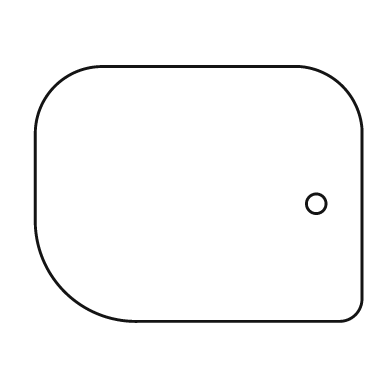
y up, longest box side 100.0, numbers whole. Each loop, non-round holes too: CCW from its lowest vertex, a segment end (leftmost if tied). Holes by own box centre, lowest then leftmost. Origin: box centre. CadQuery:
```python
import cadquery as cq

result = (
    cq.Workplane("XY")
    .moveTo(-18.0, -39.0)
    .lineTo(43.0, -39.0)
    .threePointArc((48.0, -37.0), (50.0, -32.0))
    .lineTo(50.0, 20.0)
    .threePointArc((44.0, 33.0), (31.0, 39.0))
    .lineTo(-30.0, 39.0)
    .threePointArc((-44.0, 33.0), (-50.0, 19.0))
    .lineTo(-50.0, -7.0)
    .threePointArc((-41.0, -30.0), (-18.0, -39.0))
    .close()
    .moveTo(36.0, -3.0)
    .circle(3.0)
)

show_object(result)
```